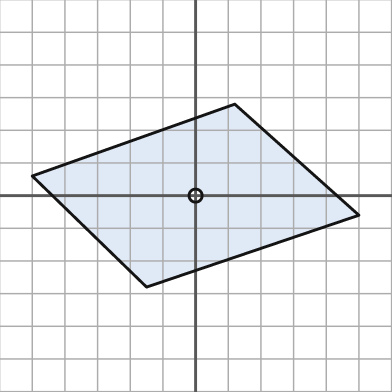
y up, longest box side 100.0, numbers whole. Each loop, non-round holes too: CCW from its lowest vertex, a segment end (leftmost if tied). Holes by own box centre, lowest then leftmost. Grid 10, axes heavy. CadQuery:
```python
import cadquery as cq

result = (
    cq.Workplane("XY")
    .moveTo(-15.0, -28.0)
    .lineTo(50.0, -6.0)
    .lineTo(12.0, 28.0)
    .lineTo(-50.0, 6.0)
    .close()
    .moveTo(0.0, 0.0)
    .circle(2.0)
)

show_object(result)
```